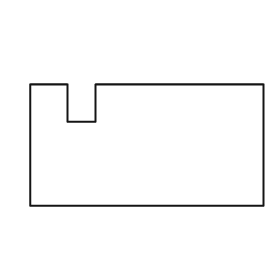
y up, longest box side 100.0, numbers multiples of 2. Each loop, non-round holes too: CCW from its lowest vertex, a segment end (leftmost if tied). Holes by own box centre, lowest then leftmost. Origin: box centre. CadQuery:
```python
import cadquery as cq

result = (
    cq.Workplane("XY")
    .moveTo(-50.0, -26.0)
    .lineTo(50.0, -26.0)
    .lineTo(50.0, 26.0)
    .lineTo(-22.0, 26.0)
    .lineTo(-22.0, 10.0)
    .lineTo(-34.0, 10.0)
    .lineTo(-34.0, 26.0)
    .lineTo(-50.0, 26.0)
    .close()
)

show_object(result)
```